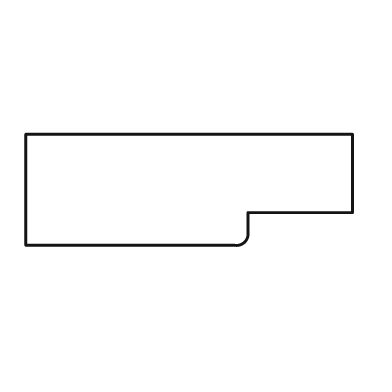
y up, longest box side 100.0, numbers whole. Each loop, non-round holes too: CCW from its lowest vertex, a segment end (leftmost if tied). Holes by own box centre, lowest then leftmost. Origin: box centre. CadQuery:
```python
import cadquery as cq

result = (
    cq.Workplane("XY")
    .moveTo(-50.0, -17.0)
    .lineTo(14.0, -17.0)
    .threePointArc((17.0, -16.0), (18.0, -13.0))
    .lineTo(18.0, -7.0)
    .lineTo(50.0, -7.0)
    .lineTo(50.0, 17.0)
    .lineTo(-50.0, 17.0)
    .close()
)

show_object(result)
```